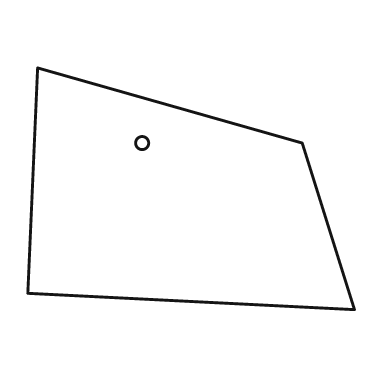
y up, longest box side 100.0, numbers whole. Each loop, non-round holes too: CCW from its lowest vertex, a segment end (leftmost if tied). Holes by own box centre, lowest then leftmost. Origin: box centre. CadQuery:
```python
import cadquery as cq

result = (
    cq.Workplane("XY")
    .moveTo(50.0, -37.0)
    .lineTo(34.0, 14.0)
    .lineTo(-47.0, 37.0)
    .lineTo(-50.0, -32.0)
    .close()
    .moveTo(-15.0, 14.0)
    .circle(2.0)
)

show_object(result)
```